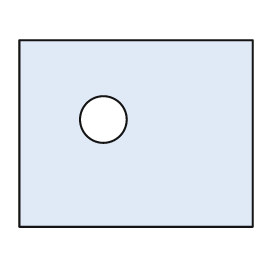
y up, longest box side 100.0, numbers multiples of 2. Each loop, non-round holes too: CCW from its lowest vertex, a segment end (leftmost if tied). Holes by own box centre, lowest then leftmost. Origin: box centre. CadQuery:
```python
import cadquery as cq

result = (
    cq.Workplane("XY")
    .moveTo(-50.0, -40.0)
    .lineTo(50.0, -40.0)
    .lineTo(50.0, 40.0)
    .lineTo(-50.0, 40.0)
    .close()
    .moveTo(-14.0, 6.0)
    .circle(10.0)
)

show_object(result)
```